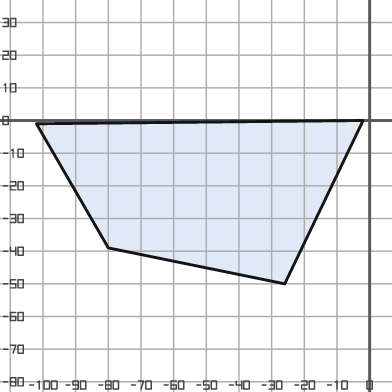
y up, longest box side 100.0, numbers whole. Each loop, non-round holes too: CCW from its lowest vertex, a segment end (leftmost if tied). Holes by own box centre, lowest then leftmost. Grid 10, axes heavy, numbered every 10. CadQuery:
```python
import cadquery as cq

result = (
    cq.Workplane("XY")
    .moveTo(-26.0, -50.0)
    .lineTo(-2.0, 0.0)
    .lineTo(-102.0, -1.0)
    .lineTo(-80.0, -39.0)
    .close()
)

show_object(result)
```